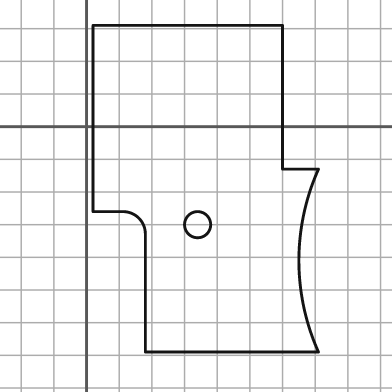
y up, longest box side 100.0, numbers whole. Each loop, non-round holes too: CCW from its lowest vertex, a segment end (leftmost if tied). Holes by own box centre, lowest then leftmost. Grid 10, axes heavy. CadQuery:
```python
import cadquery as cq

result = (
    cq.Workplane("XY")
    .moveTo(18.0, -69.0)
    .lineTo(71.0, -69.0)
    .threePointArc((65.0, -41.0), (71.0, -13.0))
    .lineTo(60.0, -13.0)
    .lineTo(60.0, 31.0)
    .lineTo(2.0, 31.0)
    .lineTo(2.0, -26.0)
    .lineTo(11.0, -26.0)
    .threePointArc((16.0, -28.0), (18.0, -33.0))
    .close()
    .moveTo(34.0, -30.0)
    .circle(4.0)
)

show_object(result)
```